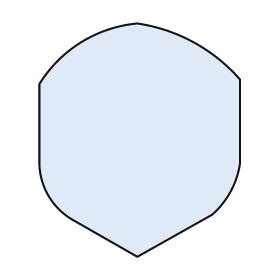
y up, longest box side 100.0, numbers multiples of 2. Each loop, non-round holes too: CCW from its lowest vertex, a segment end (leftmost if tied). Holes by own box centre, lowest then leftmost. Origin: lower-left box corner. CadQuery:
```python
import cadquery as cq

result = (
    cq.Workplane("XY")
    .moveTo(42.0, 0.0)
    .lineTo(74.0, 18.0)
    .threePointArc((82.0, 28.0), (86.0, 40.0))
    .lineTo(86.0, 76.0)
    .threePointArc((66.0, 92.0), (42.0, 100.0))
    .threePointArc((18.0, 92.0), (0.0, 74.0))
    .lineTo(0.0, 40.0)
    .threePointArc((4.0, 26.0), (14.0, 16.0))
    .close()
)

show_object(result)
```